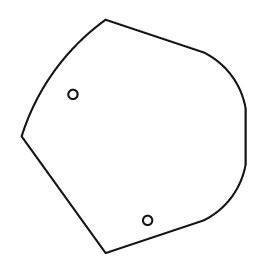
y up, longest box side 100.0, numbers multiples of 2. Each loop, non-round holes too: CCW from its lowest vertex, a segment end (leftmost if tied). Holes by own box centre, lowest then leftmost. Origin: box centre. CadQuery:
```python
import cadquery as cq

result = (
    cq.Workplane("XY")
    .moveTo(-12.0, -50.0)
    .lineTo(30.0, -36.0)
    .threePointArc((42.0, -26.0), (48.0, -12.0))
    .lineTo(48.0, 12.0)
    .threePointArc((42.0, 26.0), (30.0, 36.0))
    .lineTo(-12.0, 50.0)
    .threePointArc((-34.0, 28.0), (-48.0, 0.0))
    .close()
    .moveTo(6.0, -36.0)
    .circle(2.0)
    .moveTo(-26.0, 18.0)
    .circle(2.0)
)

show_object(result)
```